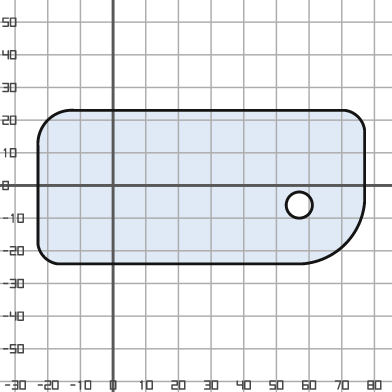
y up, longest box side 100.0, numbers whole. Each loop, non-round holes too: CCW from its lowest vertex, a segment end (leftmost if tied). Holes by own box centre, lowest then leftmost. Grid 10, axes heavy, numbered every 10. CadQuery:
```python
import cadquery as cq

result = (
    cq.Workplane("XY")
    .moveTo(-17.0, -24.0)
    .lineTo(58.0, -24.0)
    .threePointArc((71.0, -18.0), (77.0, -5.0))
    .lineTo(77.0, 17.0)
    .threePointArc((75.0, 21.0), (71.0, 23.0))
    .lineTo(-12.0, 23.0)
    .threePointArc((-20.0, 20.0), (-23.0, 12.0))
    .lineTo(-23.0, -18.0)
    .threePointArc((-21.0, -22.0), (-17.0, -24.0))
    .close()
    .moveTo(57.0, -6.0)
    .circle(4.0)
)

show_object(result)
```